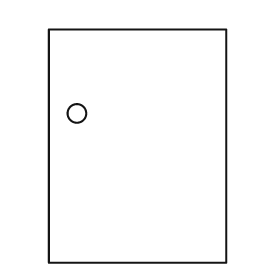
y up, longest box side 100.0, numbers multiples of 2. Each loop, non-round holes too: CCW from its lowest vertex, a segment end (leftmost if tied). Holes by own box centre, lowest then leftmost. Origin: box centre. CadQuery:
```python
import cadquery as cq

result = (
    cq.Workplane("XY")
    .moveTo(-38.0, -50.0)
    .lineTo(38.0, -50.0)
    .lineTo(38.0, 50.0)
    .lineTo(-38.0, 50.0)
    .close()
    .moveTo(-26.0, 14.0)
    .circle(4.0)
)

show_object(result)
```